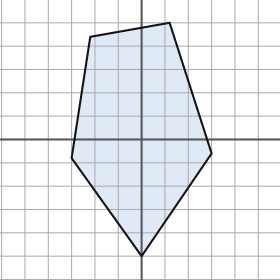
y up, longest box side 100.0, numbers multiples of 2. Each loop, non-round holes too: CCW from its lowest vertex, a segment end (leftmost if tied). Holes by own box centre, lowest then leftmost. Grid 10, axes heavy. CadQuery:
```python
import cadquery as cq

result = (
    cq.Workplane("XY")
    .moveTo(0.0, -50.0)
    .lineTo(30.0, -6.0)
    .lineTo(12.0, 50.0)
    .lineTo(-22.0, 44.0)
    .lineTo(-30.0, -8.0)
    .close()
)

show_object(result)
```